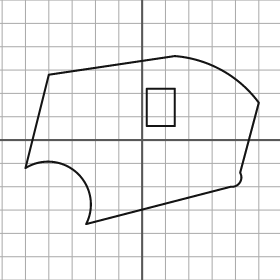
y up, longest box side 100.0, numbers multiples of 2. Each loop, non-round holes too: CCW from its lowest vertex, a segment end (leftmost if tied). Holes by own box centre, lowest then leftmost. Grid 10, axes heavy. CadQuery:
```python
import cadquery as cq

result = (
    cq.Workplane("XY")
    .moveTo(-24.0, -36.0)
    .lineTo(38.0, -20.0)
    .threePointArc((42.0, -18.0), (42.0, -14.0))
    .lineTo(50.0, 16.0)
    .threePointArc((34.0, 30.0), (14.0, 36.0))
    .lineTo(-40.0, 28.0)
    .lineTo(-50.0, -12.0)
    .threePointArc((-28.0, -14.0), (-24.0, -36.0))
    .close()
    .moveTo(2.0, 6.0)
    .lineTo(14.0, 6.0)
    .lineTo(14.0, 22.0)
    .lineTo(2.0, 22.0)
    .close()
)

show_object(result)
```